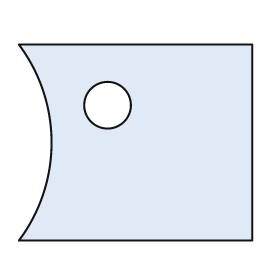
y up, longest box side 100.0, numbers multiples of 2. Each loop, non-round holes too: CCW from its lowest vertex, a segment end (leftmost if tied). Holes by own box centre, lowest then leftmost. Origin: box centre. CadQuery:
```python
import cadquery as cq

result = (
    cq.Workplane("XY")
    .moveTo(-50.0, -42.0)
    .lineTo(50.0, -42.0)
    .lineTo(50.0, 42.0)
    .lineTo(-50.0, 42.0)
    .threePointArc((-36.0, 0.0), (-50.0, -42.0))
    .close()
    .moveTo(-12.0, 16.0)
    .circle(10.0)
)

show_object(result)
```